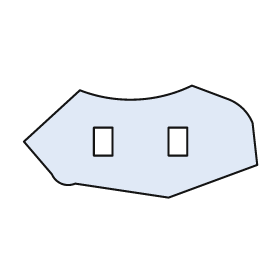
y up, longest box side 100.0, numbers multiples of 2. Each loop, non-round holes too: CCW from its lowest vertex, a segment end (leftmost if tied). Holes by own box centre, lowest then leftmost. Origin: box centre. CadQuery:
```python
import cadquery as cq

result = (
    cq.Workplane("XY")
    .moveTo(12.0, -24.0)
    .lineTo(50.0, -10.0)
    .lineTo(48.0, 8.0)
    .threePointArc((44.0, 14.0), (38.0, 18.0))
    .lineTo(22.0, 24.0)
    .threePointArc((-2.0, 18.0), (-26.0, 22.0))
    .lineTo(-50.0, 0.0)
    .lineTo(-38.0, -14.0)
    .threePointArc((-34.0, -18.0), (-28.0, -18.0))
    .close()
    .moveTo(-20.0, -6.0)
    .lineTo(-12.0, -6.0)
    .lineTo(-12.0, 6.0)
    .lineTo(-20.0, 6.0)
    .close()
    .moveTo(12.0, -6.0)
    .lineTo(20.0, -6.0)
    .lineTo(20.0, 6.0)
    .lineTo(12.0, 6.0)
    .close()
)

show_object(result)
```